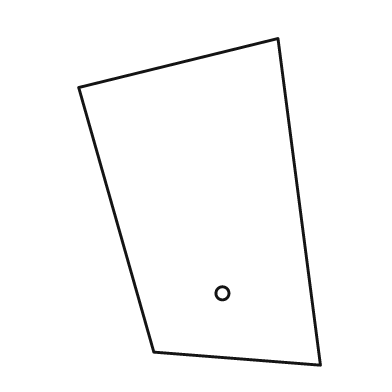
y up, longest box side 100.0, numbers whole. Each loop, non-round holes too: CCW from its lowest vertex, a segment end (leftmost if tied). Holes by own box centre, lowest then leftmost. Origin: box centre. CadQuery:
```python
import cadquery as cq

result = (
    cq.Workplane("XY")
    .moveTo(37.0, -50.0)
    .lineTo(24.0, 50.0)
    .lineTo(-37.0, 35.0)
    .lineTo(-14.0, -46.0)
    .close()
    .moveTo(7.0, -28.0)
    .circle(2.0)
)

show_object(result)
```